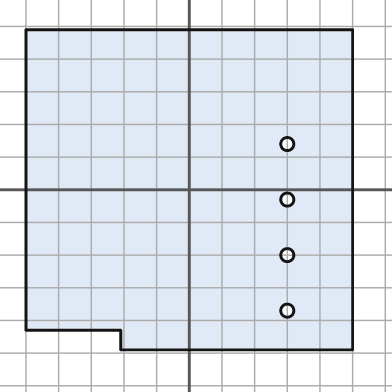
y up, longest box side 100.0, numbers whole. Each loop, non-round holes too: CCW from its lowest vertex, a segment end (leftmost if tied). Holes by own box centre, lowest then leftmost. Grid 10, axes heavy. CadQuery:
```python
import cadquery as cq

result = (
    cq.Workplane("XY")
    .moveTo(-21.0, -49.0)
    .lineTo(50.0, -49.0)
    .lineTo(50.0, 49.0)
    .lineTo(-50.0, 49.0)
    .lineTo(-50.0, -43.0)
    .lineTo(-21.0, -43.0)
    .close()
    .moveTo(30.0, -37.0)
    .circle(2.0)
    .moveTo(30.0, -20.0)
    .circle(2.0)
    .moveTo(30.0, -3.0)
    .circle(2.0)
    .moveTo(30.0, 14.0)
    .circle(2.0)
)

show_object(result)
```